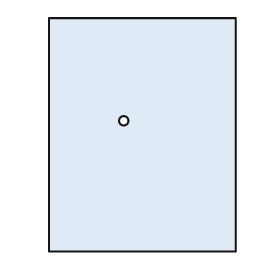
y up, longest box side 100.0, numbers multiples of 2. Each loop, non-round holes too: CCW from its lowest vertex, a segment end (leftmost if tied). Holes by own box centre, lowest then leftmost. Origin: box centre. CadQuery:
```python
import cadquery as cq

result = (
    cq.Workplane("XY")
    .moveTo(-40.0, -50.0)
    .lineTo(40.0, -50.0)
    .lineTo(40.0, 50.0)
    .lineTo(-40.0, 50.0)
    .close()
    .moveTo(-8.0, 6.0)
    .circle(2.0)
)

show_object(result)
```